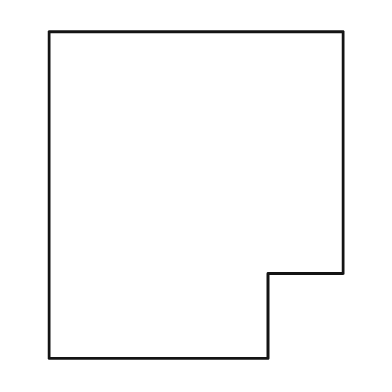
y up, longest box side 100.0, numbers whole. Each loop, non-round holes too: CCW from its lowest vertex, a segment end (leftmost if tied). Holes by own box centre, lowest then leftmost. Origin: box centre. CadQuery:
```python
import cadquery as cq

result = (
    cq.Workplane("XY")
    .moveTo(-45.0, -50.0)
    .lineTo(22.0, -50.0)
    .lineTo(22.0, -24.0)
    .lineTo(45.0, -24.0)
    .lineTo(45.0, 50.0)
    .lineTo(-45.0, 50.0)
    .close()
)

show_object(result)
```